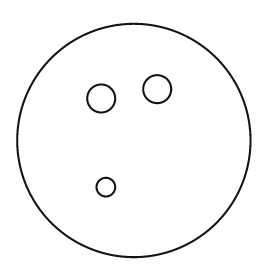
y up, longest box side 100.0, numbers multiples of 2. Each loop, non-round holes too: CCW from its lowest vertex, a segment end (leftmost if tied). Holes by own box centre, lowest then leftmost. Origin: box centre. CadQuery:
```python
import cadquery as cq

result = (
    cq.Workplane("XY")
    .moveTo(0.0, 0.0)
    .circle(50.0)
    .moveTo(-12.0, -20.0)
    .circle(4.0)
    .moveTo(-14.0, 18.0)
    .circle(6.0)
    .moveTo(10.0, 22.0)
    .circle(6.0)
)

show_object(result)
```